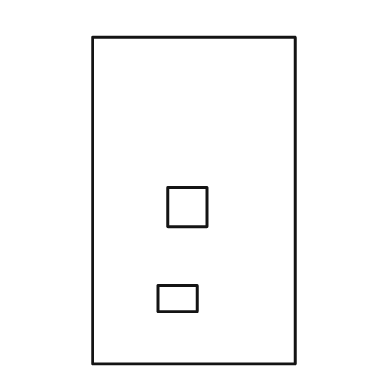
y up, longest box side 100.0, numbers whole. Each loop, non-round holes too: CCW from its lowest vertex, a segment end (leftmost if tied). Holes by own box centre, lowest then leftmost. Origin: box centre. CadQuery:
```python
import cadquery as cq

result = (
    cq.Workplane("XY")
    .moveTo(-31.0, -50.0)
    .lineTo(31.0, -50.0)
    .lineTo(31.0, 50.0)
    .lineTo(-31.0, 50.0)
    .close()
    .moveTo(-11.0, -34.0)
    .lineTo(1.0, -34.0)
    .lineTo(1.0, -26.0)
    .lineTo(-11.0, -26.0)
    .close()
    .moveTo(-8.0, -8.0)
    .lineTo(4.0, -8.0)
    .lineTo(4.0, 4.0)
    .lineTo(-8.0, 4.0)
    .close()
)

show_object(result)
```